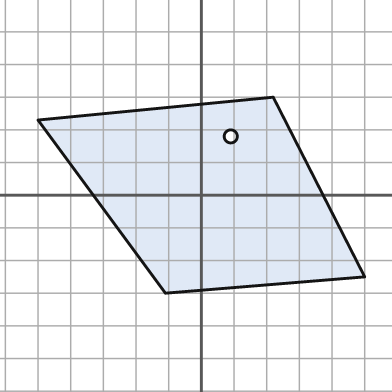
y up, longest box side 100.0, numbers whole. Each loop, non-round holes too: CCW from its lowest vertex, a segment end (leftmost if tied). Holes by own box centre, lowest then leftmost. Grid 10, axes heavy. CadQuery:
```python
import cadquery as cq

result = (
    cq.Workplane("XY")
    .moveTo(-11.0, -30.0)
    .lineTo(50.0, -25.0)
    .lineTo(22.0, 30.0)
    .lineTo(-50.0, 23.0)
    .close()
    .moveTo(9.0, 18.0)
    .circle(2.0)
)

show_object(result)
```